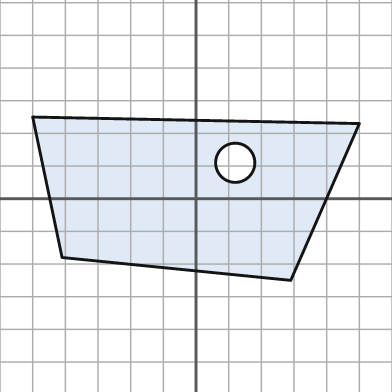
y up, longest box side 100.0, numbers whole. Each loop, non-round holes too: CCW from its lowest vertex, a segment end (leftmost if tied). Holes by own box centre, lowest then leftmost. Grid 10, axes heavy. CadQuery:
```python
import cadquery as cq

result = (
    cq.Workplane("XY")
    .moveTo(29.0, -25.0)
    .lineTo(50.0, 23.0)
    .lineTo(-50.0, 25.0)
    .lineTo(-41.0, -18.0)
    .close()
    .moveTo(12.0, 11.0)
    .circle(6.0)
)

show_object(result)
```